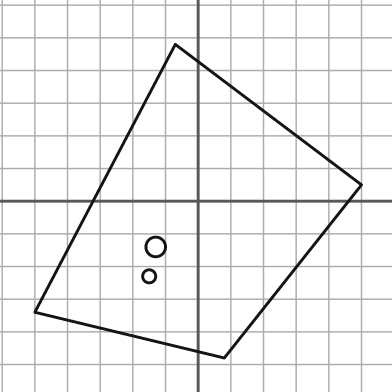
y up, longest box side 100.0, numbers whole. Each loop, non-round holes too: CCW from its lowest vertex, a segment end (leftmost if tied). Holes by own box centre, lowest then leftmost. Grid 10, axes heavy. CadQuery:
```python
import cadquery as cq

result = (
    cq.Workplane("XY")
    .moveTo(8.0, -48.0)
    .lineTo(50.0, 5.0)
    .lineTo(-7.0, 48.0)
    .lineTo(-50.0, -34.0)
    .close()
    .moveTo(-15.0, -23.0)
    .circle(2.0)
    .moveTo(-13.0, -14.0)
    .circle(3.0)
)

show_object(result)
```